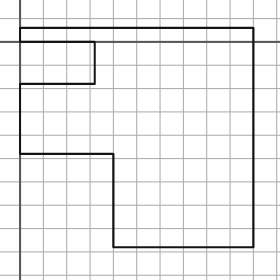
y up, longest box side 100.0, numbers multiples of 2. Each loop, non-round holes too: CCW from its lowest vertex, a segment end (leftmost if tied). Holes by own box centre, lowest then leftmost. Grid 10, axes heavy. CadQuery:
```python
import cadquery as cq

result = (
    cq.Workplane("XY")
    .moveTo(40.0, -88.0)
    .lineTo(100.0, -88.0)
    .lineTo(100.0, 6.0)
    .lineTo(0.0, 6.0)
    .lineTo(0.0, 0.0)
    .lineTo(32.0, 0.0)
    .lineTo(32.0, -18.0)
    .lineTo(0.0, -18.0)
    .lineTo(0.0, -48.0)
    .lineTo(40.0, -48.0)
    .close()
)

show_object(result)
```